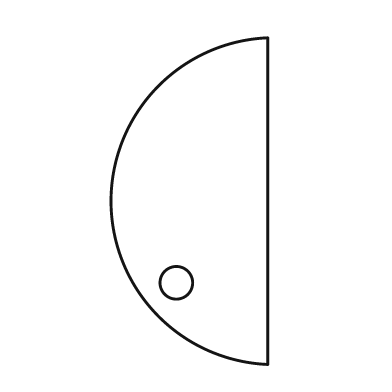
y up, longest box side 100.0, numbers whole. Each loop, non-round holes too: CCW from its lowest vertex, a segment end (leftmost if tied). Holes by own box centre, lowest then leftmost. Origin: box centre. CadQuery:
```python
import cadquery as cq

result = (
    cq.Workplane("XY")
    .moveTo(24.0, -50.0)
    .lineTo(24.0, 50.0)
    .threePointArc((-24.0, 0.0), (24.0, -50.0))
    .close()
    .moveTo(-4.0, -25.0)
    .circle(5.0)
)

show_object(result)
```